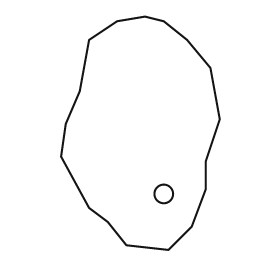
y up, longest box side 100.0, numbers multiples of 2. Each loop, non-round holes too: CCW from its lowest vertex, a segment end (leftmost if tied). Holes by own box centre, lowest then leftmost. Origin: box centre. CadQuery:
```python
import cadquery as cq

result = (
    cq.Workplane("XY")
    .moveTo(12.0, -50.0)
    .lineTo(22.0, -40.0)
    .lineTo(28.0, -24.0)
    .lineTo(28.0, -12.0)
    .lineTo(34.0, 6.0)
    .lineTo(30.0, 28.0)
    .lineTo(20.0, 40.0)
    .lineTo(10.0, 48.0)
    .lineTo(2.0, 50.0)
    .lineTo(-10.0, 48.0)
    .lineTo(-22.0, 40.0)
    .lineTo(-26.0, 18.0)
    .lineTo(-32.0, 4.0)
    .lineTo(-34.0, -10.0)
    .lineTo(-22.0, -32.0)
    .lineTo(-14.0, -38.0)
    .lineTo(-6.0, -48.0)
    .close()
    .moveTo(10.0, -26.0)
    .circle(4.0)
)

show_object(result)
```